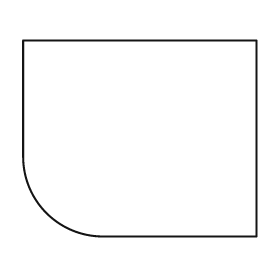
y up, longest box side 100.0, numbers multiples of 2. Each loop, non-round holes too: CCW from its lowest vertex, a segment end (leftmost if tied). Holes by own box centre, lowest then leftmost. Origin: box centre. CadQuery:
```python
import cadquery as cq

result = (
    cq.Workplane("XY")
    .moveTo(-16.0, -42.0)
    .lineTo(50.0, -42.0)
    .lineTo(50.0, 42.0)
    .lineTo(-50.0, 42.0)
    .lineTo(-50.0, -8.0)
    .threePointArc((-40.0, -32.0), (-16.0, -42.0))
    .close()
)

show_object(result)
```